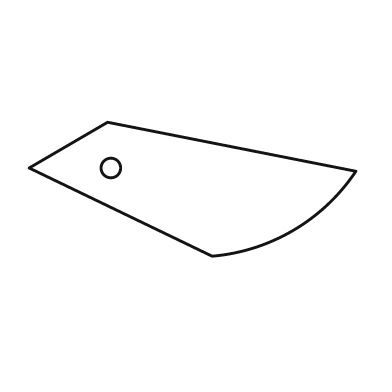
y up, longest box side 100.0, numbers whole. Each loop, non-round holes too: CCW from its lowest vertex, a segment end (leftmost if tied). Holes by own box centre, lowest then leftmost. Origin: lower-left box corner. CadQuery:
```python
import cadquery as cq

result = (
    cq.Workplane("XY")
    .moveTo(56.0, 0.0)
    .threePointArc((81.0, 8.0), (100.0, 26.0))
    .lineTo(24.0, 41.0)
    .lineTo(0.0, 27.0)
    .close()
    .moveTo(25.0, 27.0)
    .circle(3.0)
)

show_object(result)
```